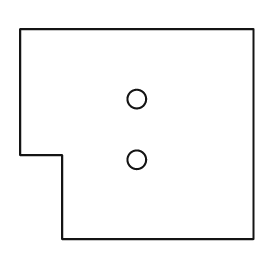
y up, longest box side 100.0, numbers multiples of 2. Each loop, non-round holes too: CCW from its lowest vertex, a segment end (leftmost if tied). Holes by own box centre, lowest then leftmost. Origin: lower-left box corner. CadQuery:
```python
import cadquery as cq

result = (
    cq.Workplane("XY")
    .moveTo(18.0, 0.0)
    .lineTo(100.0, 0.0)
    .lineTo(100.0, 90.0)
    .lineTo(0.0, 90.0)
    .lineTo(0.0, 36.0)
    .lineTo(18.0, 36.0)
    .close()
    .moveTo(50.0, 34.0)
    .circle(4.0)
    .moveTo(50.0, 60.0)
    .circle(4.0)
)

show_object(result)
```